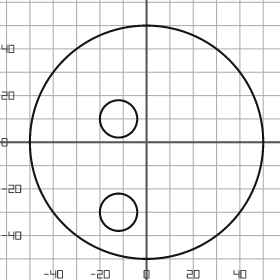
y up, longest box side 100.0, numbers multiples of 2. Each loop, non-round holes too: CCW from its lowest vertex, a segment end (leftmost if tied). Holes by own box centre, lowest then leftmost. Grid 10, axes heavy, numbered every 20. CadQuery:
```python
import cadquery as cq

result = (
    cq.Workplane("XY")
    .moveTo(0.0, 0.0)
    .circle(50.0)
    .moveTo(-12.0, -30.0)
    .circle(8.0)
    .moveTo(-12.0, 10.0)
    .circle(8.0)
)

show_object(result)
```